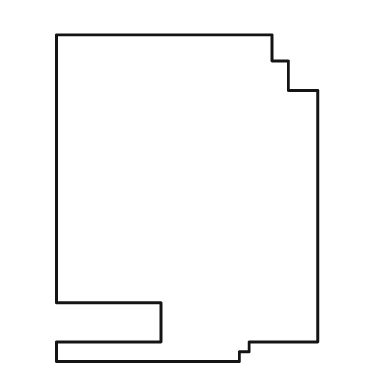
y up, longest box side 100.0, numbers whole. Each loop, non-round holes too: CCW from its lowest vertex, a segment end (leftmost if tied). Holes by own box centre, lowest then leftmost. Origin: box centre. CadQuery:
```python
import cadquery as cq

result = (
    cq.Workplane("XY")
    .moveTo(-40.0, -50.0)
    .lineTo(16.0, -50.0)
    .lineTo(16.0, -47.0)
    .lineTo(19.0, -47.0)
    .lineTo(19.0, -44.0)
    .lineTo(40.0, -44.0)
    .lineTo(40.0, 33.0)
    .lineTo(31.0, 33.0)
    .lineTo(31.0, 42.0)
    .lineTo(26.0, 42.0)
    .lineTo(26.0, 50.0)
    .lineTo(-40.0, 50.0)
    .lineTo(-40.0, -32.0)
    .lineTo(-8.0, -32.0)
    .lineTo(-8.0, -44.0)
    .lineTo(-40.0, -44.0)
    .close()
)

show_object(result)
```